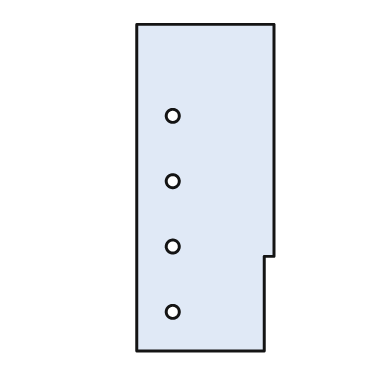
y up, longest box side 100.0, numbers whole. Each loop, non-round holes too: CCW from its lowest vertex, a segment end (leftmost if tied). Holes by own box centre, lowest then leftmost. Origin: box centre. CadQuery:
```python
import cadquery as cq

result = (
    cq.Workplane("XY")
    .moveTo(-21.0, -50.0)
    .lineTo(18.0, -50.0)
    .lineTo(18.0, -21.0)
    .lineTo(21.0, -21.0)
    .lineTo(21.0, 50.0)
    .lineTo(-21.0, 50.0)
    .close()
    .moveTo(-10.0, -38.0)
    .circle(2.0)
    .moveTo(-10.0, -18.0)
    .circle(2.0)
    .moveTo(-10.0, 2.0)
    .circle(2.0)
    .moveTo(-10.0, 22.0)
    .circle(2.0)
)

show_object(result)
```